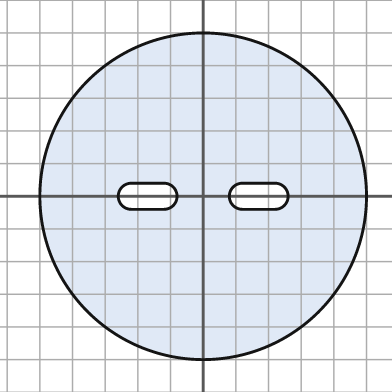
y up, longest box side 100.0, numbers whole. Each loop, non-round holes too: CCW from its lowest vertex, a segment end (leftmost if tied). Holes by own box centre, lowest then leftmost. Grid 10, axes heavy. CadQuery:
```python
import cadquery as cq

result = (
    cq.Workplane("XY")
    .moveTo(0.0, 0.0)
    .circle(50.0)
    .moveTo(-22.0, -4.0)
    .lineTo(-12.0, -4.0)
    .threePointArc((-8.0, 0.0), (-12.0, 4.0))
    .lineTo(-22.0, 4.0)
    .threePointArc((-26.0, 0.0), (-22.0, -4.0))
    .close()
    .moveTo(12.0, -4.0)
    .lineTo(22.0, -4.0)
    .threePointArc((26.0, 0.0), (22.0, 4.0))
    .lineTo(12.0, 4.0)
    .threePointArc((8.0, 0.0), (12.0, -4.0))
    .close()
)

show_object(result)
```